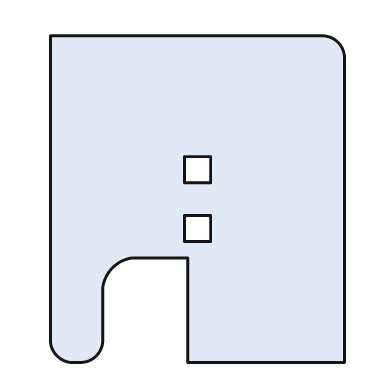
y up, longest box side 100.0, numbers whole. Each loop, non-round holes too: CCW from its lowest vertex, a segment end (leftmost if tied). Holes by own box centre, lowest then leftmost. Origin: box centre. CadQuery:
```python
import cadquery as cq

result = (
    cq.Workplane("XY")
    .moveTo(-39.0, -50.0)
    .lineTo(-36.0, -50.0)
    .threePointArc((-31.0, -48.0), (-29.0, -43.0))
    .lineTo(-29.0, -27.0)
    .threePointArc((-26.0, -21.0), (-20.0, -18.0))
    .lineTo(-3.0, -18.0)
    .lineTo(-3.0, -50.0)
    .lineTo(45.0, -50.0)
    .lineTo(45.0, 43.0)
    .threePointArc((43.0, 48.0), (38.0, 50.0))
    .lineTo(-45.0, 50.0)
    .lineTo(-45.0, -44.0)
    .threePointArc((-43.0, -48.0), (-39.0, -50.0))
    .close()
    .moveTo(-4.0, -13.0)
    .lineTo(4.0, -13.0)
    .lineTo(4.0, -5.0)
    .lineTo(-4.0, -5.0)
    .close()
    .moveTo(-4.0, 5.0)
    .lineTo(4.0, 5.0)
    .lineTo(4.0, 13.0)
    .lineTo(-4.0, 13.0)
    .close()
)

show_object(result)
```